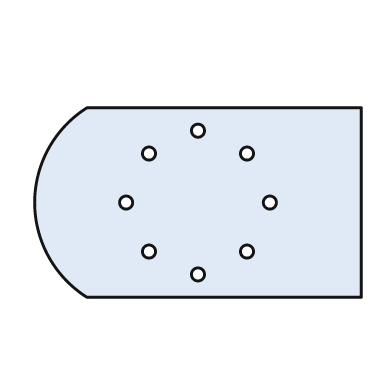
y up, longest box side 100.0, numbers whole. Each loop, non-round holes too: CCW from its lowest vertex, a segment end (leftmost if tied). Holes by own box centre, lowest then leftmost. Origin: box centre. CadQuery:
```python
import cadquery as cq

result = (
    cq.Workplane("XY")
    .moveTo(-34.0, -29.0)
    .lineTo(50.0, -29.0)
    .lineTo(50.0, 29.0)
    .lineTo(-34.0, 29.0)
    .threePointArc((-50.0, 0.0), (-34.0, -29.0))
    .close()
    .moveTo(0.0, -22.0)
    .circle(2.0)
    .moveTo(-15.0, -15.0)
    .circle(2.0)
    .moveTo(15.0, -15.0)
    .circle(2.0)
    .moveTo(-22.0, 0.0)
    .circle(2.0)
    .moveTo(22.0, 0.0)
    .circle(2.0)
    .moveTo(-15.0, 15.0)
    .circle(2.0)
    .moveTo(15.0, 15.0)
    .circle(2.0)
    .moveTo(0.0, 22.0)
    .circle(2.0)
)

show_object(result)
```